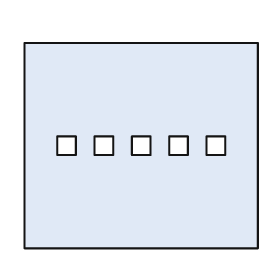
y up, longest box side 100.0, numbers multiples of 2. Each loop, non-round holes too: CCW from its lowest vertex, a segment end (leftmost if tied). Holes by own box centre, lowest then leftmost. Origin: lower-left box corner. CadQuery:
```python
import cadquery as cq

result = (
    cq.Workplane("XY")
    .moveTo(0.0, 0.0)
    .lineTo(100.0, 0.0)
    .lineTo(100.0, 88.0)
    .lineTo(0.0, 88.0)
    .close()
    .moveTo(14.0, 40.0)
    .lineTo(22.0, 40.0)
    .lineTo(22.0, 48.0)
    .lineTo(14.0, 48.0)
    .close()
    .moveTo(30.0, 40.0)
    .lineTo(38.0, 40.0)
    .lineTo(38.0, 48.0)
    .lineTo(30.0, 48.0)
    .close()
    .moveTo(46.0, 40.0)
    .lineTo(54.0, 40.0)
    .lineTo(54.0, 48.0)
    .lineTo(46.0, 48.0)
    .close()
    .moveTo(62.0, 40.0)
    .lineTo(70.0, 40.0)
    .lineTo(70.0, 48.0)
    .lineTo(62.0, 48.0)
    .close()
    .moveTo(78.0, 40.0)
    .lineTo(86.0, 40.0)
    .lineTo(86.0, 48.0)
    .lineTo(78.0, 48.0)
    .close()
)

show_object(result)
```